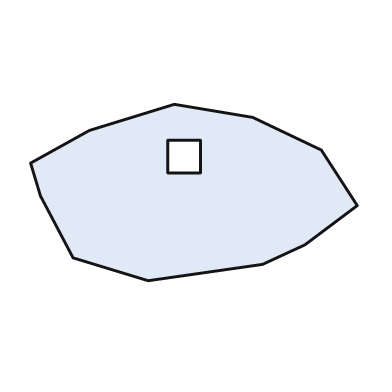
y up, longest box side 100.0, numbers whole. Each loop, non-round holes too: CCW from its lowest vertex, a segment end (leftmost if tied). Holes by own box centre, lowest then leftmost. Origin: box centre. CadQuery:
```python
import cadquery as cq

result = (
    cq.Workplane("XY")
    .moveTo(-14.0, -27.0)
    .lineTo(21.0, -22.0)
    .lineTo(34.0, -16.0)
    .lineTo(50.0, -4.0)
    .lineTo(39.0, 13.0)
    .lineTo(18.0, 23.0)
    .lineTo(-6.0, 27.0)
    .lineTo(-32.0, 19.0)
    .lineTo(-50.0, 9.0)
    .lineTo(-47.0, -1.0)
    .lineTo(-37.0, -20.0)
    .close()
    .moveTo(-8.0, 6.0)
    .lineTo(2.0, 6.0)
    .lineTo(2.0, 16.0)
    .lineTo(-8.0, 16.0)
    .close()
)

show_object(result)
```